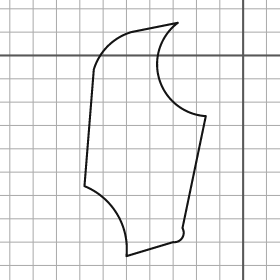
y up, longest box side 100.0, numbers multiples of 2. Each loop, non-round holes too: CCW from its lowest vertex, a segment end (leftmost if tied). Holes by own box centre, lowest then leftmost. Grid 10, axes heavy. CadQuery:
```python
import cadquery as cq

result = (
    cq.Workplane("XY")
    .moveTo(-50.0, -86.0)
    .lineTo(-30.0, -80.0)
    .threePointArc((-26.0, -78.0), (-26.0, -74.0))
    .lineTo(-16.0, -26.0)
    .threePointArc((-36.0, -10.0), (-28.0, 14.0))
    .lineTo(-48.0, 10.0)
    .threePointArc((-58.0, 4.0), (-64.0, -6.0))
    .lineTo(-68.0, -56.0)
    .threePointArc((-54.0, -68.0), (-50.0, -86.0))
    .close()
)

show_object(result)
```